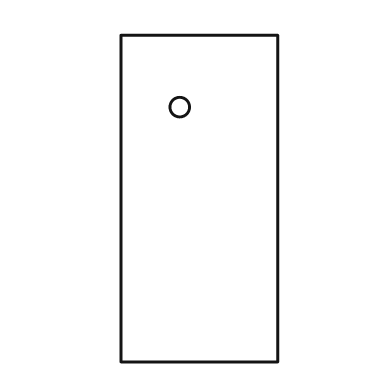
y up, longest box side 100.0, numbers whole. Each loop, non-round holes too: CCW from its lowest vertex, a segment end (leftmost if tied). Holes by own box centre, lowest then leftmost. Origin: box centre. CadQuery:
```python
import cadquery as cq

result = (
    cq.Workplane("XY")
    .moveTo(-24.0, -50.0)
    .lineTo(24.0, -50.0)
    .lineTo(24.0, 50.0)
    .lineTo(-24.0, 50.0)
    .close()
    .moveTo(-6.0, 28.0)
    .circle(3.0)
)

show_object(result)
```